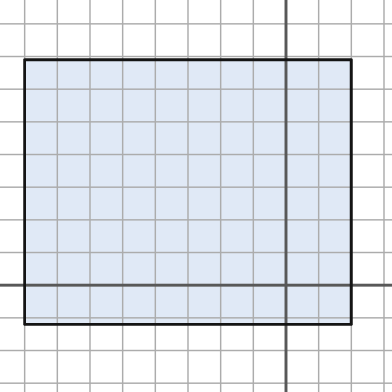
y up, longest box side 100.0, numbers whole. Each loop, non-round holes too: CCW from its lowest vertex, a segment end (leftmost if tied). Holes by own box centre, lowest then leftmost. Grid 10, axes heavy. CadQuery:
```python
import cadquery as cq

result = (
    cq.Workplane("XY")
    .moveTo(-80.0, -12.0)
    .lineTo(20.0, -12.0)
    .lineTo(20.0, 69.0)
    .lineTo(-80.0, 69.0)
    .close()
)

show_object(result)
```